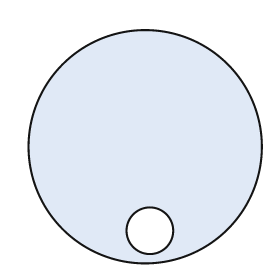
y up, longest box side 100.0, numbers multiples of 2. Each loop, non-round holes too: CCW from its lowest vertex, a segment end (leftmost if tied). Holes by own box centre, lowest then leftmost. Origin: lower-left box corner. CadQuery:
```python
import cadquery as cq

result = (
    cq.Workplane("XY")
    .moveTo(50.0, 50.0)
    .circle(50.0)
    .moveTo(52.0, 14.0)
    .circle(10.0)
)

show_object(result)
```